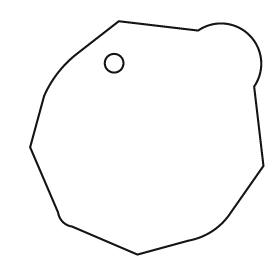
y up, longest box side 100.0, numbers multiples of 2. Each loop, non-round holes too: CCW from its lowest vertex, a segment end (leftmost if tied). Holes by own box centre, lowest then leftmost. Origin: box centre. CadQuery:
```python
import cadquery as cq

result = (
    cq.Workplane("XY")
    .moveTo(-4.0, -50.0)
    .lineTo(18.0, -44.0)
    .threePointArc((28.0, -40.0), (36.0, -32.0))
    .lineTo(50.0, -12.0)
    .lineTo(46.0, 22.0)
    .threePointArc((44.0, 44.0), (22.0, 46.0))
    .lineTo(-12.0, 50.0)
    .lineTo(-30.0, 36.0)
    .threePointArc((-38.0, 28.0), (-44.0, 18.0))
    .lineTo(-50.0, -4.0)
    .lineTo(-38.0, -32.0)
    .threePointArc((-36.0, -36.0), (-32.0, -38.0))
    .close()
    .moveTo(-14.0, 32.0)
    .circle(4.0)
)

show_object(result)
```